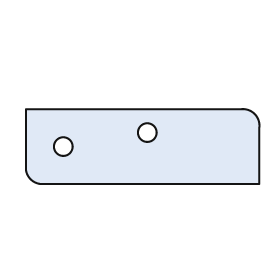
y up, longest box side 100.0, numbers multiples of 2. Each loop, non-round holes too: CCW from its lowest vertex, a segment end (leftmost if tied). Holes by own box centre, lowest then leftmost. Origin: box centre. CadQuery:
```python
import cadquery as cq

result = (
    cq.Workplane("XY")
    .moveTo(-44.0, -16.0)
    .lineTo(50.0, -16.0)
    .lineTo(50.0, 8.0)
    .threePointArc((48.0, 14.0), (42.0, 16.0))
    .lineTo(-50.0, 16.0)
    .lineTo(-50.0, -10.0)
    .threePointArc((-48.0, -14.0), (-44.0, -16.0))
    .close()
    .moveTo(-34.0, 0.0)
    .circle(4.0)
    .moveTo(2.0, 6.0)
    .circle(4.0)
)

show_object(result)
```